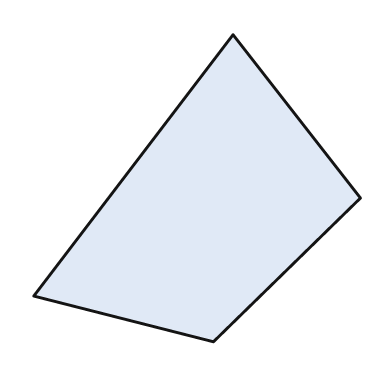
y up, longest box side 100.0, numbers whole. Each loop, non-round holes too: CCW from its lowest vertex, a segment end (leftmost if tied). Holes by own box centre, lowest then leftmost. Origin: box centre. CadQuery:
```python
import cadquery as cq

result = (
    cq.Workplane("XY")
    .moveTo(5.0, -47.0)
    .lineTo(50.0, -3.0)
    .lineTo(11.0, 47.0)
    .lineTo(-50.0, -33.0)
    .close()
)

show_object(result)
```